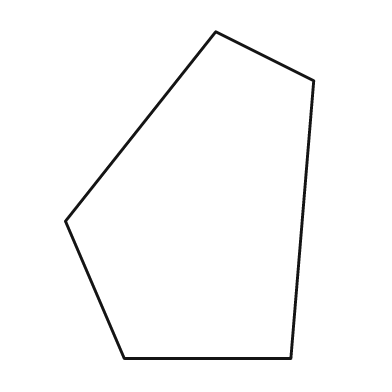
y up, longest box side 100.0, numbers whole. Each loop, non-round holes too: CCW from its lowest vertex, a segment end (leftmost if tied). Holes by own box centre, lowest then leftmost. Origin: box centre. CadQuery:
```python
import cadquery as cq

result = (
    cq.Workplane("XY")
    .moveTo(-20.0, -50.0)
    .lineTo(31.0, -50.0)
    .lineTo(38.0, 35.0)
    .lineTo(8.0, 50.0)
    .lineTo(-38.0, -8.0)
    .close()
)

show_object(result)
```